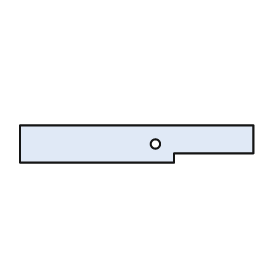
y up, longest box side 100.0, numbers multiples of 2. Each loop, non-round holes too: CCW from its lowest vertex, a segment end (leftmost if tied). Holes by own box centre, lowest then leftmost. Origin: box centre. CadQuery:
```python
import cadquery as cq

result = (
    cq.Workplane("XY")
    .moveTo(-50.0, -8.0)
    .lineTo(16.0, -8.0)
    .lineTo(16.0, -4.0)
    .lineTo(50.0, -4.0)
    .lineTo(50.0, 8.0)
    .lineTo(-50.0, 8.0)
    .close()
    .moveTo(8.0, 0.0)
    .circle(2.0)
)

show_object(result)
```